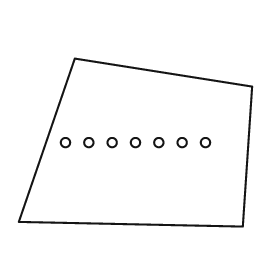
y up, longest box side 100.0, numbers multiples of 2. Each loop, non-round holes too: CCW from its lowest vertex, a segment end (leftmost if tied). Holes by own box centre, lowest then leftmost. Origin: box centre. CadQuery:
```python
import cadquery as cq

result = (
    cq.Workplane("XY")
    .moveTo(46.0, -36.0)
    .lineTo(50.0, 24.0)
    .lineTo(-26.0, 36.0)
    .lineTo(-50.0, -34.0)
    .close()
    .moveTo(-30.0, 0.0)
    .circle(2.0)
    .moveTo(-20.0, 0.0)
    .circle(2.0)
    .moveTo(-10.0, 0.0)
    .circle(2.0)
    .moveTo(0.0, 0.0)
    .circle(2.0)
    .moveTo(10.0, 0.0)
    .circle(2.0)
    .moveTo(20.0, 0.0)
    .circle(2.0)
    .moveTo(30.0, 0.0)
    .circle(2.0)
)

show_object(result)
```